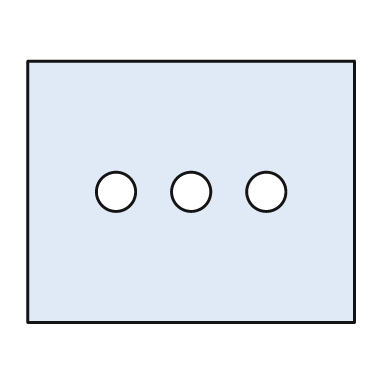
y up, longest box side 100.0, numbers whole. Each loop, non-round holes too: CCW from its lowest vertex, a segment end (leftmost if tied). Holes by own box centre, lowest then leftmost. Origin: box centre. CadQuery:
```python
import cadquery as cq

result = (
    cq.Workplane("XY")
    .moveTo(-50.0, -40.0)
    .lineTo(50.0, -40.0)
    .lineTo(50.0, 40.0)
    .lineTo(-50.0, 40.0)
    .close()
    .moveTo(-23.0, 0.0)
    .circle(6.0)
    .moveTo(0.0, 0.0)
    .circle(6.0)
    .moveTo(23.0, 0.0)
    .circle(6.0)
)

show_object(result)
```